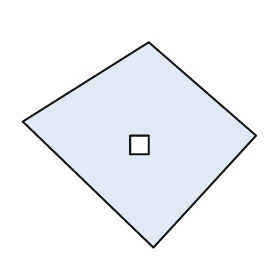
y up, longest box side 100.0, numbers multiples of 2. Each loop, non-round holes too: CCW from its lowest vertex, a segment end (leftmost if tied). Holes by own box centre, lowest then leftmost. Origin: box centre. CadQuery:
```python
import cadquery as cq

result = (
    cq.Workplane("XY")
    .moveTo(6.0, -44.0)
    .lineTo(50.0, 4.0)
    .lineTo(4.0, 44.0)
    .lineTo(-50.0, 10.0)
    .close()
    .moveTo(-4.0, -4.0)
    .lineTo(4.0, -4.0)
    .lineTo(4.0, 4.0)
    .lineTo(-4.0, 4.0)
    .close()
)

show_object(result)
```